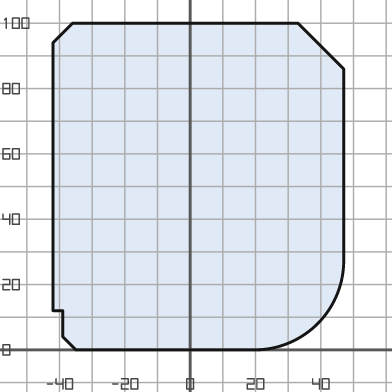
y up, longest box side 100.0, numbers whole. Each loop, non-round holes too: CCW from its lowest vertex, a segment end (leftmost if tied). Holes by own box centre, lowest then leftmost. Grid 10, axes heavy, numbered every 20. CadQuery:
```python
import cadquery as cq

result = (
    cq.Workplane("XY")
    .moveTo(-35.0, 0.0)
    .lineTo(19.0, 0.0)
    .threePointArc((39.0, 8.0), (47.0, 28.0))
    .lineTo(47.0, 86.0)
    .lineTo(33.0, 100.0)
    .lineTo(-36.0, 100.0)
    .lineTo(-42.0, 94.0)
    .lineTo(-42.0, 12.0)
    .lineTo(-39.0, 12.0)
    .lineTo(-39.0, 4.0)
    .close()
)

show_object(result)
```